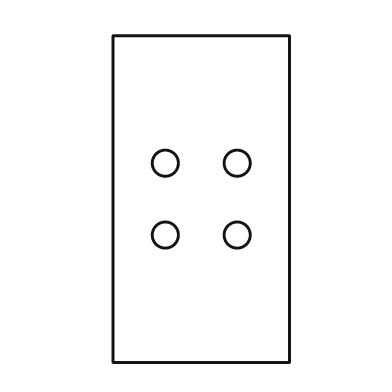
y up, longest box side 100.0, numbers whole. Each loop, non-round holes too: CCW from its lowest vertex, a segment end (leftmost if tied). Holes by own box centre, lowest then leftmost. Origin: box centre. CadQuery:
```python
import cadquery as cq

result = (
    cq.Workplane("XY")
    .moveTo(-27.0, -50.0)
    .lineTo(27.0, -50.0)
    .lineTo(27.0, 50.0)
    .lineTo(-27.0, 50.0)
    .close()
    .moveTo(-11.0, -11.0)
    .circle(4.0)
    .moveTo(11.0, -11.0)
    .circle(4.0)
    .moveTo(-11.0, 11.0)
    .circle(4.0)
    .moveTo(11.0, 11.0)
    .circle(4.0)
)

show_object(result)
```